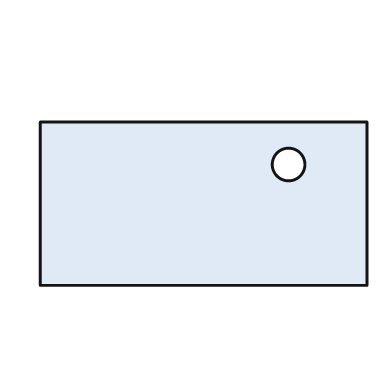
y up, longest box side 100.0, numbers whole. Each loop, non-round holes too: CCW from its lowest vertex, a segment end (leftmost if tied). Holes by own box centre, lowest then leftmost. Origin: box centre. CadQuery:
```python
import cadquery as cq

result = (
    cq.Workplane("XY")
    .moveTo(-50.0, -25.0)
    .lineTo(50.0, -25.0)
    .lineTo(50.0, 25.0)
    .lineTo(-50.0, 25.0)
    .close()
    .moveTo(26.0, 12.0)
    .circle(5.0)
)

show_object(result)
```